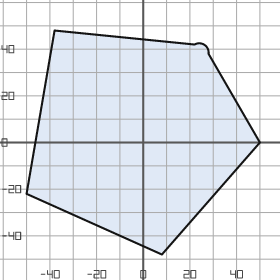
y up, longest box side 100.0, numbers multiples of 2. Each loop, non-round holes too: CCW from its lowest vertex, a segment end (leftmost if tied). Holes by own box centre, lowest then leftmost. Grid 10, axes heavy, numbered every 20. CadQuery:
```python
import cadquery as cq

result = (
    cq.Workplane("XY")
    .moveTo(8.0, -48.0)
    .lineTo(50.0, 0.0)
    .lineTo(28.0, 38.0)
    .threePointArc((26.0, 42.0), (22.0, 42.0))
    .lineTo(-38.0, 48.0)
    .lineTo(-50.0, -22.0)
    .close()
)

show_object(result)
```